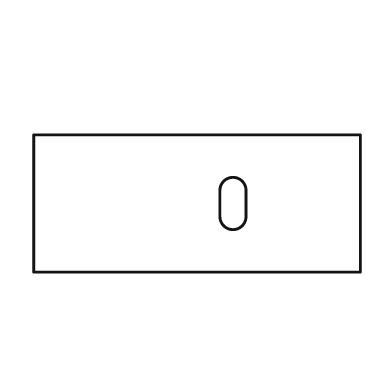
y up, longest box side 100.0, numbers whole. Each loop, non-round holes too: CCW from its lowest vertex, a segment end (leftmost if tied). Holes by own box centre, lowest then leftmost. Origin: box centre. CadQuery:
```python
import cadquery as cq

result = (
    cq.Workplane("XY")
    .moveTo(-50.0, -21.0)
    .lineTo(50.0, -21.0)
    .lineTo(50.0, 21.0)
    .lineTo(-50.0, 21.0)
    .close()
    .moveTo(7.0, -4.0)
    .threePointArc((11.0, -8.0), (15.0, -4.0))
    .lineTo(15.0, 4.0)
    .threePointArc((11.0, 8.0), (7.0, 4.0))
    .close()
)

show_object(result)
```